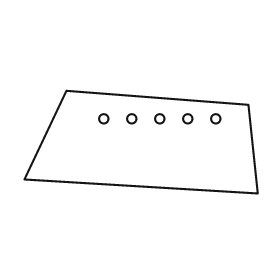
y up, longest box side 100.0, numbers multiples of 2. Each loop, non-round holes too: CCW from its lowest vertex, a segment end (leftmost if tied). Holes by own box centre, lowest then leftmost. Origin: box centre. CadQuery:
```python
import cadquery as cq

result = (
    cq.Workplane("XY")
    .moveTo(50.0, -22.0)
    .lineTo(46.0, 16.0)
    .lineTo(-32.0, 22.0)
    .lineTo(-50.0, -16.0)
    .close()
    .moveTo(-16.0, 10.0)
    .circle(2.0)
    .moveTo(-4.0, 10.0)
    .circle(2.0)
    .moveTo(8.0, 10.0)
    .circle(2.0)
    .moveTo(20.0, 10.0)
    .circle(2.0)
    .moveTo(32.0, 10.0)
    .circle(2.0)
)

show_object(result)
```